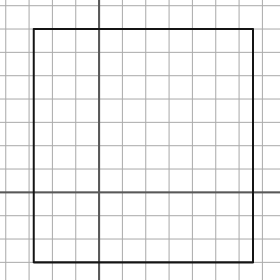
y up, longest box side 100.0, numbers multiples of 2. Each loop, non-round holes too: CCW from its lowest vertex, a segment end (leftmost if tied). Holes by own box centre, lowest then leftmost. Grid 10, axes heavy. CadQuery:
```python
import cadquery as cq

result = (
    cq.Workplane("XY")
    .moveTo(-28.0, -30.0)
    .lineTo(66.0, -30.0)
    .lineTo(66.0, 70.0)
    .lineTo(-28.0, 70.0)
    .close()
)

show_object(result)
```